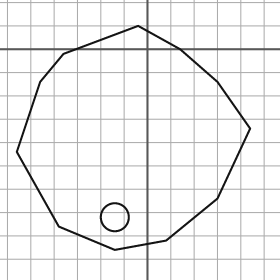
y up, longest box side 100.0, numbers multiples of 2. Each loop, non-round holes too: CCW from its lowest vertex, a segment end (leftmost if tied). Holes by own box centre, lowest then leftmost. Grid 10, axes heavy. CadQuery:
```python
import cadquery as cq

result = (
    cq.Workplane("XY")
    .moveTo(-14.0, -86.0)
    .lineTo(8.0, -82.0)
    .lineTo(30.0, -64.0)
    .lineTo(44.0, -34.0)
    .lineTo(30.0, -14.0)
    .lineTo(14.0, 0.0)
    .lineTo(-4.0, 10.0)
    .lineTo(-36.0, -2.0)
    .lineTo(-46.0, -14.0)
    .lineTo(-56.0, -44.0)
    .lineTo(-38.0, -76.0)
    .close()
    .moveTo(-14.0, -72.0)
    .circle(6.0)
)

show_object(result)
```